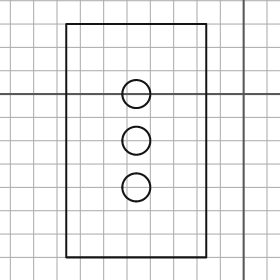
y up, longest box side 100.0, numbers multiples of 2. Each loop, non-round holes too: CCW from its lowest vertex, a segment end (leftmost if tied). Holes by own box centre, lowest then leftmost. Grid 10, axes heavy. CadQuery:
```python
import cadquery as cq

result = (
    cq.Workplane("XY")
    .moveTo(-76.0, -70.0)
    .lineTo(-16.0, -70.0)
    .lineTo(-16.0, 30.0)
    .lineTo(-76.0, 30.0)
    .close()
    .moveTo(-46.0, -40.0)
    .circle(6.0)
    .moveTo(-46.0, -20.0)
    .circle(6.0)
    .moveTo(-46.0, 0.0)
    .circle(6.0)
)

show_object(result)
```